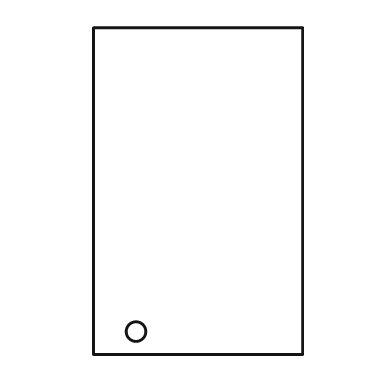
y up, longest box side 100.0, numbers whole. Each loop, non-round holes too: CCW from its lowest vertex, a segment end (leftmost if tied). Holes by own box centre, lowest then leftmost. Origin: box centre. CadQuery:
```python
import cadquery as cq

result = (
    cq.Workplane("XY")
    .moveTo(-32.0, -50.0)
    .lineTo(32.0, -50.0)
    .lineTo(32.0, 50.0)
    .lineTo(-32.0, 50.0)
    .close()
    .moveTo(-19.0, -43.0)
    .circle(3.0)
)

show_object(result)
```